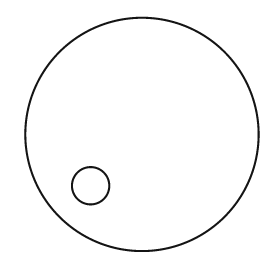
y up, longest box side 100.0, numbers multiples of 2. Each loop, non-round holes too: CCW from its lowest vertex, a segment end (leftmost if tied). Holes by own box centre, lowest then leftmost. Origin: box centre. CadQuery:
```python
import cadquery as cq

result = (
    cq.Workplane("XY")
    .moveTo(0.0, 0.0)
    .circle(50.0)
    .moveTo(-22.0, -22.0)
    .circle(8.0)
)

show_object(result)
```